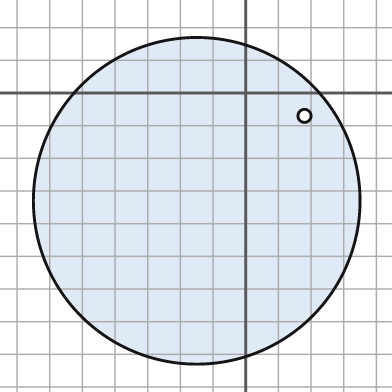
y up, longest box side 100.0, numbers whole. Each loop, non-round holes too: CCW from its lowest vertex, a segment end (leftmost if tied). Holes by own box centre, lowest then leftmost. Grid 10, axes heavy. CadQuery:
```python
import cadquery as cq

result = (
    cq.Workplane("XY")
    .moveTo(-15.0, -33.0)
    .circle(50.0)
    .moveTo(18.0, -7.0)
    .circle(2.0)
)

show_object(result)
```